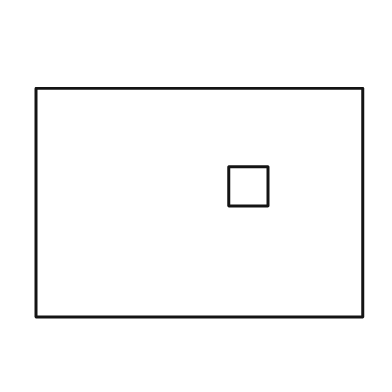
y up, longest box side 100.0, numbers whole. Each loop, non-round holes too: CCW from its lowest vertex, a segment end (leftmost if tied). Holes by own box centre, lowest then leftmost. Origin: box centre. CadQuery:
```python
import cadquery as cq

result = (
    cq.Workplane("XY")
    .moveTo(-50.0, -35.0)
    .lineTo(50.0, -35.0)
    .lineTo(50.0, 35.0)
    .lineTo(-50.0, 35.0)
    .close()
    .moveTo(9.0, -1.0)
    .lineTo(21.0, -1.0)
    .lineTo(21.0, 11.0)
    .lineTo(9.0, 11.0)
    .close()
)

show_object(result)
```